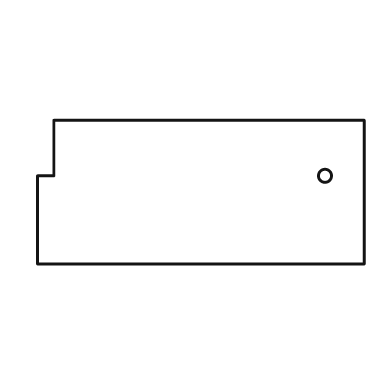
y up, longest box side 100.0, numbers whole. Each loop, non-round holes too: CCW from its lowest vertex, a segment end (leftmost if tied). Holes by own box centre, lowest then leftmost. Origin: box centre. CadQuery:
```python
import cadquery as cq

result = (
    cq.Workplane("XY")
    .moveTo(-50.0, -22.0)
    .lineTo(50.0, -22.0)
    .lineTo(50.0, 22.0)
    .lineTo(-45.0, 22.0)
    .lineTo(-45.0, 5.0)
    .lineTo(-50.0, 5.0)
    .close()
    .moveTo(38.0, 5.0)
    .circle(2.0)
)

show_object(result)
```